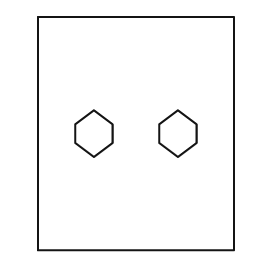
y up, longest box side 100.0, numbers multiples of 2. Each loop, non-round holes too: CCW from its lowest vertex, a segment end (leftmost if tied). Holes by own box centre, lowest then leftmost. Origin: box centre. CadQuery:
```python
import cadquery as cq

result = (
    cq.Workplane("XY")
    .moveTo(-42.0, -50.0)
    .lineTo(42.0, -50.0)
    .lineTo(42.0, 50.0)
    .lineTo(-42.0, 50.0)
    .close()
    .moveTo(-18.0, -10.0)
    .lineTo(-10.0, -4.0)
    .lineTo(-10.0, 4.0)
    .lineTo(-18.0, 10.0)
    .lineTo(-26.0, 4.0)
    .lineTo(-26.0, -4.0)
    .close()
    .moveTo(18.0, -10.0)
    .lineTo(26.0, -4.0)
    .lineTo(26.0, 4.0)
    .lineTo(18.0, 10.0)
    .lineTo(10.0, 4.0)
    .lineTo(10.0, -4.0)
    .close()
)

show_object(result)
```